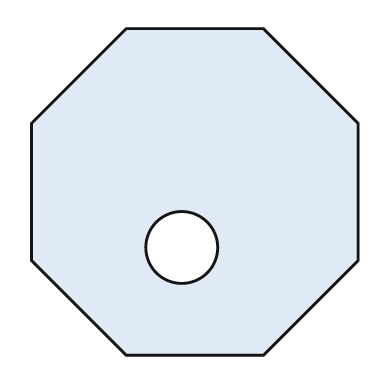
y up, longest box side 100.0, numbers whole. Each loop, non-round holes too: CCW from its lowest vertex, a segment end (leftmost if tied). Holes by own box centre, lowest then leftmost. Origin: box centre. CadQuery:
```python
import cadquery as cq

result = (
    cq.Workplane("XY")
    .moveTo(-21.0, -50.0)
    .lineTo(21.0, -50.0)
    .lineTo(50.0, -21.0)
    .lineTo(50.0, 21.0)
    .lineTo(21.0, 50.0)
    .lineTo(-21.0, 50.0)
    .lineTo(-50.0, 21.0)
    .lineTo(-50.0, -21.0)
    .close()
    .moveTo(-4.0, -17.0)
    .circle(11.0)
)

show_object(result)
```